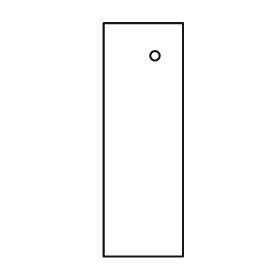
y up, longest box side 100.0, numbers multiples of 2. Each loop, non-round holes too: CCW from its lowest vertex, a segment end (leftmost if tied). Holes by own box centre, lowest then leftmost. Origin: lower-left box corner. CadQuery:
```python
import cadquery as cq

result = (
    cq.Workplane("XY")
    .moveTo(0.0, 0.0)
    .lineTo(34.0, 0.0)
    .lineTo(34.0, 100.0)
    .lineTo(0.0, 100.0)
    .close()
    .moveTo(22.0, 86.0)
    .circle(2.0)
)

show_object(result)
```